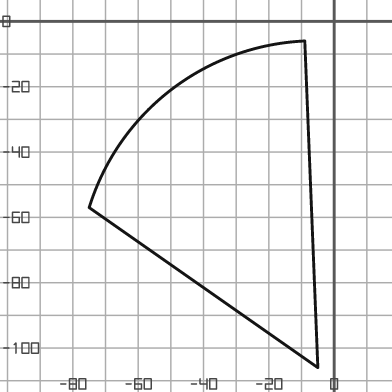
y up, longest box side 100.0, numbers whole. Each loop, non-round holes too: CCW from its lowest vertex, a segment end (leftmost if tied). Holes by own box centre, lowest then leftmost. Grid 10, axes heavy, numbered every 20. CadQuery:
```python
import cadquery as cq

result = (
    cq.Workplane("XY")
    .moveTo(-5.0, -106.0)
    .lineTo(-9.0, -6.0)
    .threePointArc((-50.0, -21.0), (-75.0, -57.0))
    .close()
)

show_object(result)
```